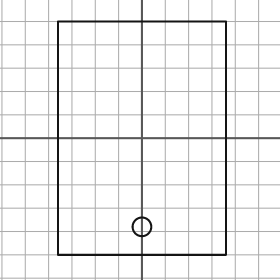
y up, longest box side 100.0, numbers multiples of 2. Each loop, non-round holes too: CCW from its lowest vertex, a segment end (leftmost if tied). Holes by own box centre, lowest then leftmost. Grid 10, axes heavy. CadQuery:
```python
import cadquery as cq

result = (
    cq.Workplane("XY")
    .moveTo(-36.0, -50.0)
    .lineTo(36.0, -50.0)
    .lineTo(36.0, 50.0)
    .lineTo(-36.0, 50.0)
    .close()
    .moveTo(0.0, -38.0)
    .circle(4.0)
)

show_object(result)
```